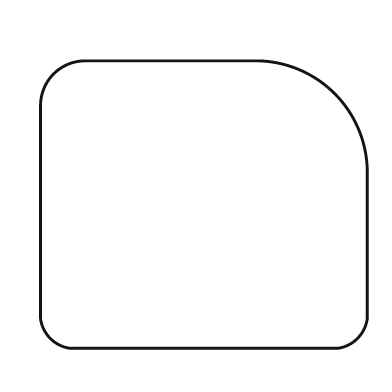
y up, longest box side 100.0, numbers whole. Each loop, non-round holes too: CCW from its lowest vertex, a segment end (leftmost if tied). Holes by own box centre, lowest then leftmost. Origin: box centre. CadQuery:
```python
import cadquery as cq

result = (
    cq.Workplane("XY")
    .moveTo(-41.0, -44.0)
    .lineTo(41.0, -44.0)
    .threePointArc((47.0, -41.0), (50.0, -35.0))
    .lineTo(50.0, 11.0)
    .threePointArc((40.0, 34.0), (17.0, 44.0))
    .lineTo(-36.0, 44.0)
    .threePointArc((-46.0, 40.0), (-50.0, 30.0))
    .lineTo(-50.0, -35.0)
    .threePointArc((-47.0, -41.0), (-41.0, -44.0))
    .close()
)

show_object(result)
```